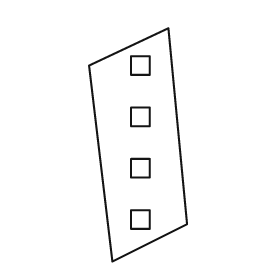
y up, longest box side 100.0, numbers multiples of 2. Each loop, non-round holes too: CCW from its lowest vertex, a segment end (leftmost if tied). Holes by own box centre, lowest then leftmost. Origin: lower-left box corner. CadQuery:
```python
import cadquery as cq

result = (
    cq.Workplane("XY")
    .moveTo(10.0, 0.0)
    .lineTo(42.0, 16.0)
    .lineTo(34.0, 100.0)
    .lineTo(0.0, 84.0)
    .close()
    .moveTo(18.0, 14.0)
    .lineTo(26.0, 14.0)
    .lineTo(26.0, 22.0)
    .lineTo(18.0, 22.0)
    .close()
    .moveTo(18.0, 36.0)
    .lineTo(26.0, 36.0)
    .lineTo(26.0, 44.0)
    .lineTo(18.0, 44.0)
    .close()
    .moveTo(18.0, 58.0)
    .lineTo(26.0, 58.0)
    .lineTo(26.0, 66.0)
    .lineTo(18.0, 66.0)
    .close()
    .moveTo(18.0, 80.0)
    .lineTo(26.0, 80.0)
    .lineTo(26.0, 88.0)
    .lineTo(18.0, 88.0)
    .close()
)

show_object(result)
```